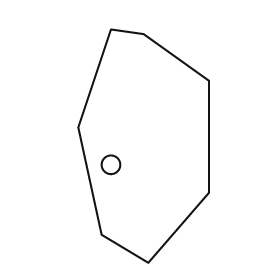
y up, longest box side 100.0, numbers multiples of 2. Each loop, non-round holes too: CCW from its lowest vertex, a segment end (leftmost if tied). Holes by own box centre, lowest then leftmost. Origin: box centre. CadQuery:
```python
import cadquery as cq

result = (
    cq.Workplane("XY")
    .moveTo(2.0, -50.0)
    .lineTo(28.0, -20.0)
    .lineTo(28.0, 28.0)
    .lineTo(0.0, 48.0)
    .lineTo(-14.0, 50.0)
    .lineTo(-28.0, 8.0)
    .lineTo(-18.0, -38.0)
    .close()
    .moveTo(-14.0, -8.0)
    .circle(4.0)
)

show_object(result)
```